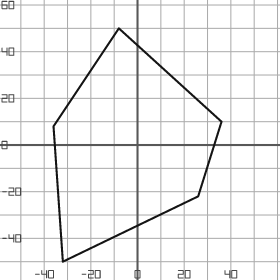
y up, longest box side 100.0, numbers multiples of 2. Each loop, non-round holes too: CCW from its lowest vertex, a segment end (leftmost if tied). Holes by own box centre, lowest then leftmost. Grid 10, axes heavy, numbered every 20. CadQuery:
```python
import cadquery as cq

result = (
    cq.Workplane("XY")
    .moveTo(-32.0, -50.0)
    .lineTo(26.0, -22.0)
    .lineTo(36.0, 10.0)
    .lineTo(-8.0, 50.0)
    .lineTo(-36.0, 8.0)
    .close()
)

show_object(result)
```